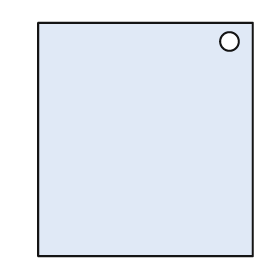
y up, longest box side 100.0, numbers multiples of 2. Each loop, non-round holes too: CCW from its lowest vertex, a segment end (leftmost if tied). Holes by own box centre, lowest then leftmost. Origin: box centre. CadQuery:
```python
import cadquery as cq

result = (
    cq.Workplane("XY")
    .moveTo(-46.0, -50.0)
    .lineTo(46.0, -50.0)
    .lineTo(46.0, 50.0)
    .lineTo(-46.0, 50.0)
    .close()
    .moveTo(36.0, 42.0)
    .circle(4.0)
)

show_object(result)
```